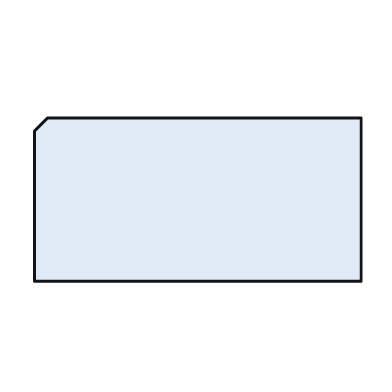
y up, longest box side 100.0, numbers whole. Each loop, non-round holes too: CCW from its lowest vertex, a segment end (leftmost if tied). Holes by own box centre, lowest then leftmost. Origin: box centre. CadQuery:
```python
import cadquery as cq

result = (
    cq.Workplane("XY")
    .moveTo(-50.0, -25.0)
    .lineTo(50.0, -25.0)
    .lineTo(50.0, 25.0)
    .lineTo(-46.0, 25.0)
    .lineTo(-50.0, 21.0)
    .close()
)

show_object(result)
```